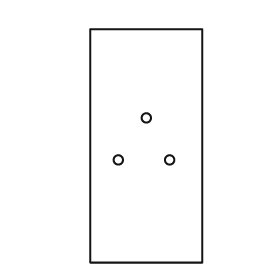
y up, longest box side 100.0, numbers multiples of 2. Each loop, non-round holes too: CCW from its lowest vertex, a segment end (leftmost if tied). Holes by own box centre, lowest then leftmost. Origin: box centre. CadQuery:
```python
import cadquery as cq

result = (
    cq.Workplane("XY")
    .moveTo(-24.0, -50.0)
    .lineTo(24.0, -50.0)
    .lineTo(24.0, 50.0)
    .lineTo(-24.0, 50.0)
    .close()
    .moveTo(-12.0, -6.0)
    .circle(2.0)
    .moveTo(10.0, -6.0)
    .circle(2.0)
    .moveTo(0.0, 12.0)
    .circle(2.0)
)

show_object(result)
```